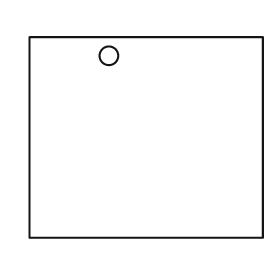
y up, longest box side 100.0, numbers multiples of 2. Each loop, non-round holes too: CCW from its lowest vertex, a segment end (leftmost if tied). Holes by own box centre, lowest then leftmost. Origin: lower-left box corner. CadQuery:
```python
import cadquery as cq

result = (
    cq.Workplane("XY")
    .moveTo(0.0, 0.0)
    .lineTo(100.0, 0.0)
    .lineTo(100.0, 86.0)
    .lineTo(0.0, 86.0)
    .close()
    .moveTo(34.0, 78.0)
    .circle(4.0)
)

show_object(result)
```